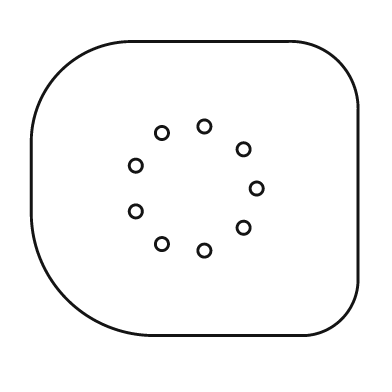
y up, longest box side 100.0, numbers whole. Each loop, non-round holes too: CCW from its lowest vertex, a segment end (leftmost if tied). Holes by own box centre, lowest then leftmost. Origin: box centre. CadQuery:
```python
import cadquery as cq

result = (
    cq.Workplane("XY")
    .moveTo(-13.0, -45.0)
    .lineTo(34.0, -45.0)
    .threePointArc((45.0, -40.0), (50.0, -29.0))
    .lineTo(50.0, 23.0)
    .threePointArc((44.0, 39.0), (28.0, 45.0))
    .lineTo(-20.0, 45.0)
    .threePointArc((-41.0, 36.0), (-50.0, 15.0))
    .lineTo(-50.0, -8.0)
    .threePointArc((-39.0, -34.0), (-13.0, -45.0))
    .close()
    .moveTo(3.0, -19.0)
    .circle(2.0)
    .moveTo(-10.0, -17.0)
    .circle(2.0)
    .moveTo(15.0, -12.0)
    .circle(2.0)
    .moveTo(-18.0, -7.0)
    .circle(2.0)
    .moveTo(19.0, 0.0)
    .circle(2.0)
    .moveTo(-18.0, 7.0)
    .circle(2.0)
    .moveTo(15.0, 12.0)
    .circle(2.0)
    .moveTo(-10.0, 17.0)
    .circle(2.0)
    .moveTo(3.0, 19.0)
    .circle(2.0)
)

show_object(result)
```